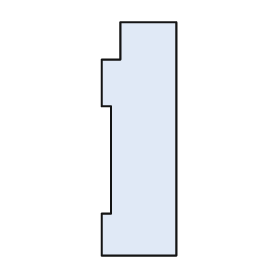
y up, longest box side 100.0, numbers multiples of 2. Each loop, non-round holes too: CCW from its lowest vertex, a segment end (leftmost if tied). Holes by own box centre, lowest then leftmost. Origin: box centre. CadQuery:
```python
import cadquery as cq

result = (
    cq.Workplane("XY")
    .moveTo(-16.0, -50.0)
    .lineTo(16.0, -50.0)
    .lineTo(16.0, 50.0)
    .lineTo(-8.0, 50.0)
    .lineTo(-8.0, 34.0)
    .lineTo(-16.0, 34.0)
    .lineTo(-16.0, 14.0)
    .lineTo(-12.0, 14.0)
    .lineTo(-12.0, -32.0)
    .lineTo(-16.0, -32.0)
    .close()
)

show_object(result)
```